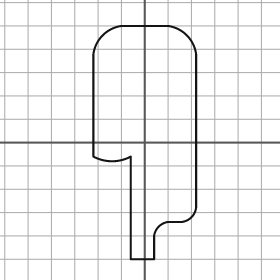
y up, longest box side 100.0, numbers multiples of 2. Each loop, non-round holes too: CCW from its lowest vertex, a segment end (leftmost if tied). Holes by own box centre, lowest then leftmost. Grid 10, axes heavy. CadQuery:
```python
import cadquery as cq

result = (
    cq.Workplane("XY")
    .moveTo(-6.0, -50.0)
    .lineTo(4.0, -50.0)
    .lineTo(4.0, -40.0)
    .threePointArc((6.0, -36.0), (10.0, -34.0))
    .lineTo(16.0, -34.0)
    .threePointArc((20.0, -32.0), (22.0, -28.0))
    .lineTo(22.0, 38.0)
    .threePointArc((18.0, 46.0), (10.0, 50.0))
    .lineTo(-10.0, 50.0)
    .threePointArc((-18.0, 46.0), (-22.0, 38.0))
    .lineTo(-22.0, -6.0)
    .threePointArc((-14.0, -8.0), (-6.0, -6.0))
    .close()
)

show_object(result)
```